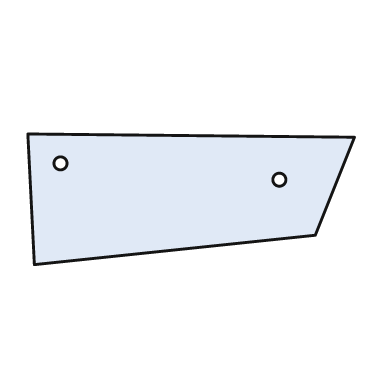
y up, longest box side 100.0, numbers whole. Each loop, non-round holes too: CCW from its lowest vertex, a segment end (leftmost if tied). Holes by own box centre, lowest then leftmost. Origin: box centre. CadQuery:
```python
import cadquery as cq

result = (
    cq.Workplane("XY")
    .moveTo(-48.0, -20.0)
    .lineTo(38.0, -11.0)
    .lineTo(50.0, 19.0)
    .lineTo(-50.0, 20.0)
    .close()
    .moveTo(27.0, 6.0)
    .circle(2.0)
    .moveTo(-40.0, 11.0)
    .circle(2.0)
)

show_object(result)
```